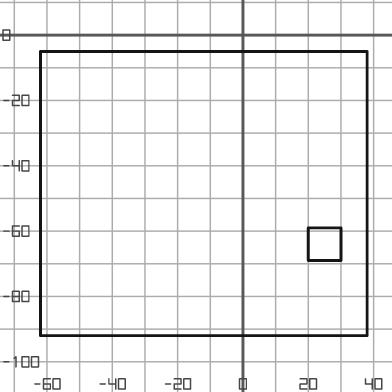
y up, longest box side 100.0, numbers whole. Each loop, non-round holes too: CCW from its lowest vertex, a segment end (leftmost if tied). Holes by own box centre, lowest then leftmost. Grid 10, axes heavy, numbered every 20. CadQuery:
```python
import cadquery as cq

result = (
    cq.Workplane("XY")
    .moveTo(-62.0, -92.0)
    .lineTo(38.0, -92.0)
    .lineTo(38.0, -5.0)
    .lineTo(-62.0, -5.0)
    .close()
    .moveTo(20.0, -69.0)
    .lineTo(30.0, -69.0)
    .lineTo(30.0, -59.0)
    .lineTo(20.0, -59.0)
    .close()
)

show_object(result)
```